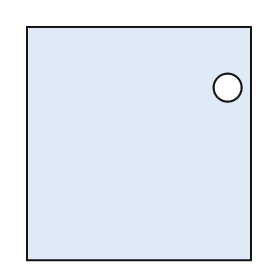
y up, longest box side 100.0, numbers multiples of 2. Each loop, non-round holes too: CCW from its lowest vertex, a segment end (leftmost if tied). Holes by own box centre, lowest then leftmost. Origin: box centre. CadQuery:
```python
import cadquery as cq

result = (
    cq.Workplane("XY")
    .moveTo(-48.0, -50.0)
    .lineTo(48.0, -50.0)
    .lineTo(48.0, 50.0)
    .lineTo(-48.0, 50.0)
    .close()
    .moveTo(38.0, 24.0)
    .circle(6.0)
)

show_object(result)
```